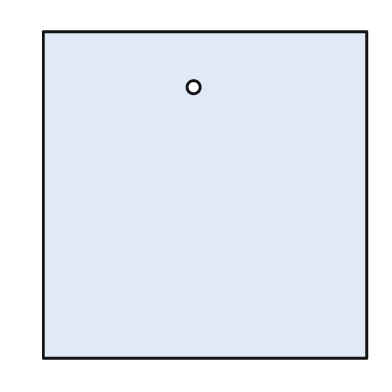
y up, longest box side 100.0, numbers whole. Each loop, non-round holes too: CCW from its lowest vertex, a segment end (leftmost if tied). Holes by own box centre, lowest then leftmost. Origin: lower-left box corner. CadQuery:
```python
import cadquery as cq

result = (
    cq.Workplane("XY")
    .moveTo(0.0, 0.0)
    .lineTo(99.0, 0.0)
    .lineTo(99.0, 100.0)
    .lineTo(0.0, 100.0)
    .close()
    .moveTo(46.0, 83.0)
    .circle(2.0)
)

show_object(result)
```